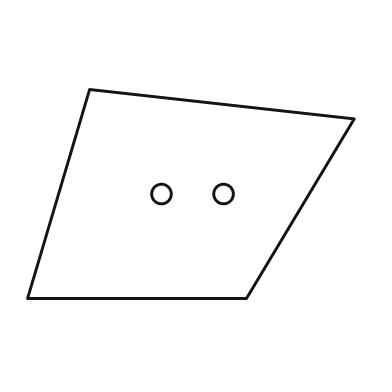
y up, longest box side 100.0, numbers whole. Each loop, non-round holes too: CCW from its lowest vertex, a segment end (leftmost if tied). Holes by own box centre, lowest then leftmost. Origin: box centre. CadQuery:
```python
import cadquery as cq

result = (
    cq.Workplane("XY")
    .moveTo(-50.0, -32.0)
    .lineTo(17.0, -32.0)
    .lineTo(50.0, 23.0)
    .lineTo(-31.0, 32.0)
    .close()
    .moveTo(-9.0, 0.0)
    .circle(3.0)
    .moveTo(10.0, 0.0)
    .circle(3.0)
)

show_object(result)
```